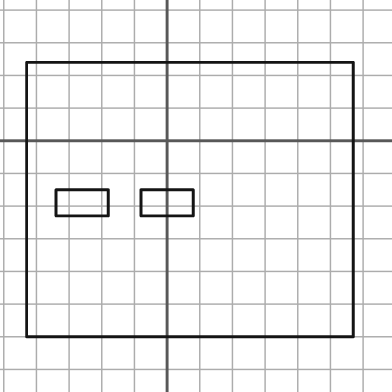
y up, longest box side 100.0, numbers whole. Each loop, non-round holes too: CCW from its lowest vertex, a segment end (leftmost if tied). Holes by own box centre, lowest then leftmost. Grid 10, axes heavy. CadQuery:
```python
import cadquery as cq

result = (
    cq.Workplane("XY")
    .moveTo(-43.0, -60.0)
    .lineTo(57.0, -60.0)
    .lineTo(57.0, 24.0)
    .lineTo(-43.0, 24.0)
    .close()
    .moveTo(-34.0, -23.0)
    .lineTo(-18.0, -23.0)
    .lineTo(-18.0, -15.0)
    .lineTo(-34.0, -15.0)
    .close()
    .moveTo(-8.0, -23.0)
    .lineTo(8.0, -23.0)
    .lineTo(8.0, -15.0)
    .lineTo(-8.0, -15.0)
    .close()
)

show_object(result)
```